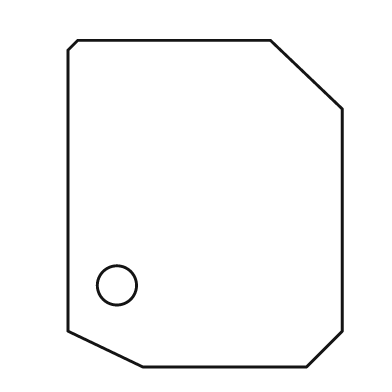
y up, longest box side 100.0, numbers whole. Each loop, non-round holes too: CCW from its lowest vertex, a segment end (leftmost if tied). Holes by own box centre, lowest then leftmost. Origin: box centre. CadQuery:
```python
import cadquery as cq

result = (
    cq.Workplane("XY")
    .moveTo(-19.0, -50.0)
    .lineTo(31.0, -50.0)
    .lineTo(42.0, -39.0)
    .lineTo(42.0, 29.0)
    .lineTo(20.0, 50.0)
    .lineTo(-39.0, 50.0)
    .lineTo(-42.0, 47.0)
    .lineTo(-42.0, -39.0)
    .close()
    .moveTo(-27.0, -25.0)
    .circle(6.0)
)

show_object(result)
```